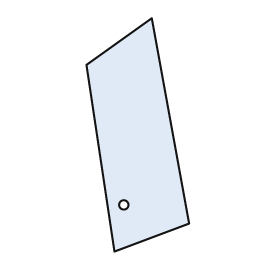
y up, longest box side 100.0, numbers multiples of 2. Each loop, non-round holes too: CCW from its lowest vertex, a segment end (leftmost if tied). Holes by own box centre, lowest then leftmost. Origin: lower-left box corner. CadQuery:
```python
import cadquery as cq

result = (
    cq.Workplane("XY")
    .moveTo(12.0, 0.0)
    .lineTo(44.0, 12.0)
    .lineTo(28.0, 100.0)
    .lineTo(0.0, 80.0)
    .close()
    .moveTo(16.0, 20.0)
    .circle(2.0)
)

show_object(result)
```